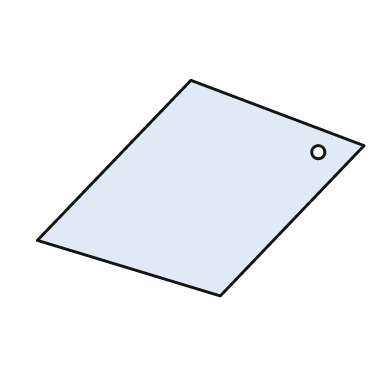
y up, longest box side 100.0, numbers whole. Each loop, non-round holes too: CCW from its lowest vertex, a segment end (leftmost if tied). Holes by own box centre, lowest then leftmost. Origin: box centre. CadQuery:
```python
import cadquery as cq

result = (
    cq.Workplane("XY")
    .moveTo(6.0, -33.0)
    .lineTo(50.0, 13.0)
    .lineTo(-3.0, 33.0)
    .lineTo(-50.0, -16.0)
    .close()
    .moveTo(36.0, 11.0)
    .circle(2.0)
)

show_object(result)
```